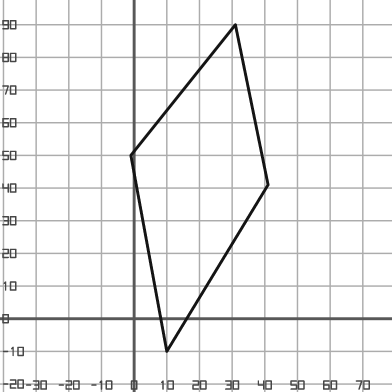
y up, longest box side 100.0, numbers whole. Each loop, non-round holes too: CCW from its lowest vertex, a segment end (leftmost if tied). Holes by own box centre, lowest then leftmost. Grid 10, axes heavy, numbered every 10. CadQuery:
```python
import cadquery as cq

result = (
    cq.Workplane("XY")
    .moveTo(10.0, -10.0)
    .lineTo(41.0, 41.0)
    .lineTo(31.0, 90.0)
    .lineTo(-1.0, 50.0)
    .close()
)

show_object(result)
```